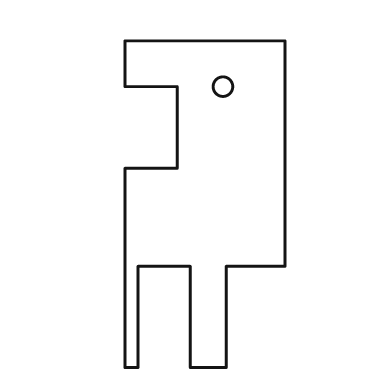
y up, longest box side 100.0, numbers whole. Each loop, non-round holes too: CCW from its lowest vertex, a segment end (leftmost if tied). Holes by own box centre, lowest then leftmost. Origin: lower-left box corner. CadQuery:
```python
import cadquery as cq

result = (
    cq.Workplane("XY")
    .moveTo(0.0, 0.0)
    .lineTo(4.0, 0.0)
    .lineTo(4.0, 31.0)
    .lineTo(20.0, 31.0)
    .lineTo(20.0, 0.0)
    .lineTo(31.0, 0.0)
    .lineTo(31.0, 31.0)
    .lineTo(49.0, 31.0)
    .lineTo(49.0, 100.0)
    .lineTo(0.0, 100.0)
    .lineTo(0.0, 86.0)
    .lineTo(16.0, 86.0)
    .lineTo(16.0, 61.0)
    .lineTo(0.0, 61.0)
    .close()
    .moveTo(30.0, 86.0)
    .circle(3.0)
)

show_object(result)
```